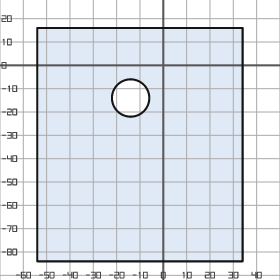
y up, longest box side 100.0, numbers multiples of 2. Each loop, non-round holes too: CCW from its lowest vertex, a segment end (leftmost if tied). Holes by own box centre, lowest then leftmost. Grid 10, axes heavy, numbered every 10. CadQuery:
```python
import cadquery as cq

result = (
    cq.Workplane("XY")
    .moveTo(-54.0, -84.0)
    .lineTo(34.0, -84.0)
    .lineTo(34.0, 16.0)
    .lineTo(-54.0, 16.0)
    .close()
    .moveTo(-14.0, -14.0)
    .circle(8.0)
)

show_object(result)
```